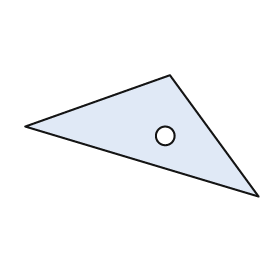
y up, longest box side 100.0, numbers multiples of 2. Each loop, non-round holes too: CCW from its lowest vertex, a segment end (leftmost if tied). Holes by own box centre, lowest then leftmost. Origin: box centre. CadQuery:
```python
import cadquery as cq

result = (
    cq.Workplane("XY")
    .moveTo(50.0, -26.0)
    .lineTo(12.0, 26.0)
    .lineTo(-50.0, 4.0)
    .close()
    .moveTo(10.0, 0.0)
    .circle(4.0)
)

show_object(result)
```